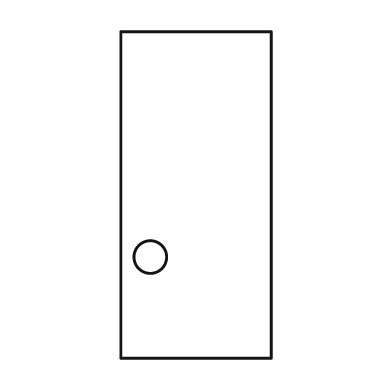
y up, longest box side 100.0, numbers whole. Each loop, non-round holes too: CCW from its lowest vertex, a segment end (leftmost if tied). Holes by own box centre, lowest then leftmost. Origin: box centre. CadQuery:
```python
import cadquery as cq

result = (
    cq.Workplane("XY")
    .moveTo(-23.0, -50.0)
    .lineTo(23.0, -50.0)
    .lineTo(23.0, 50.0)
    .lineTo(-23.0, 50.0)
    .close()
    .moveTo(-14.0, -19.0)
    .circle(5.0)
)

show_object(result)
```